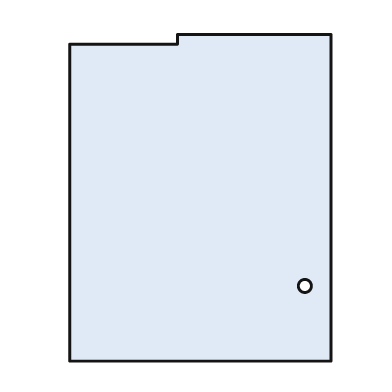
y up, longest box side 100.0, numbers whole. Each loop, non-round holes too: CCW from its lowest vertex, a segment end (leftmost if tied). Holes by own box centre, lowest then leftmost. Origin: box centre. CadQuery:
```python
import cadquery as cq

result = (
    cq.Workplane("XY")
    .moveTo(-40.0, -50.0)
    .lineTo(40.0, -50.0)
    .lineTo(40.0, 50.0)
    .lineTo(-7.0, 50.0)
    .lineTo(-7.0, 47.0)
    .lineTo(-40.0, 47.0)
    .close()
    .moveTo(32.0, -27.0)
    .circle(2.0)
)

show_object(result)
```